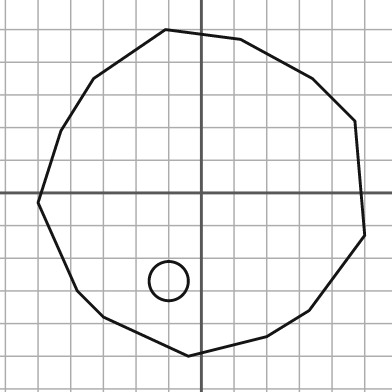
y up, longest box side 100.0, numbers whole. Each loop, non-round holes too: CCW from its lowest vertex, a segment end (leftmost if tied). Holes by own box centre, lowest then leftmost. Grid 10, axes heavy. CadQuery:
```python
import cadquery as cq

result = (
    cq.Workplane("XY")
    .moveTo(-4.0, -50.0)
    .lineTo(20.0, -44.0)
    .lineTo(33.0, -36.0)
    .lineTo(50.0, -13.0)
    .lineTo(47.0, 22.0)
    .lineTo(34.0, 35.0)
    .lineTo(12.0, 47.0)
    .lineTo(-11.0, 50.0)
    .lineTo(-33.0, 35.0)
    .lineTo(-43.0, 19.0)
    .lineTo(-50.0, -3.0)
    .lineTo(-38.0, -30.0)
    .lineTo(-30.0, -38.0)
    .close()
    .moveTo(-10.0, -27.0)
    .circle(6.0)
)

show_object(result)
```